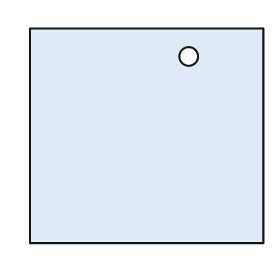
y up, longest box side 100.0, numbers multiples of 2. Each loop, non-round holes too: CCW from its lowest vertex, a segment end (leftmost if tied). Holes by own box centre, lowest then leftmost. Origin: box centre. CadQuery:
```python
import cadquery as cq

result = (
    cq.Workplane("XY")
    .moveTo(-50.0, -46.0)
    .lineTo(50.0, -46.0)
    .lineTo(50.0, 46.0)
    .lineTo(-50.0, 46.0)
    .close()
    .moveTo(18.0, 34.0)
    .circle(4.0)
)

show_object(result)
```